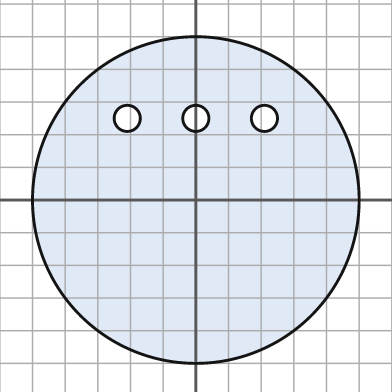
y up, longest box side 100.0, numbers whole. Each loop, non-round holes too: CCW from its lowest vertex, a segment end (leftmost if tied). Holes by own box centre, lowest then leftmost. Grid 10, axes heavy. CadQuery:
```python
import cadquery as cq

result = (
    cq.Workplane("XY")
    .moveTo(0.0, 0.0)
    .circle(50.0)
    .moveTo(-21.0, 25.0)
    .circle(4.0)
    .moveTo(0.0, 25.0)
    .circle(4.0)
    .moveTo(21.0, 25.0)
    .circle(4.0)
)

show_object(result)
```